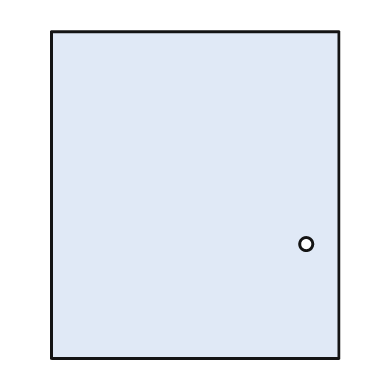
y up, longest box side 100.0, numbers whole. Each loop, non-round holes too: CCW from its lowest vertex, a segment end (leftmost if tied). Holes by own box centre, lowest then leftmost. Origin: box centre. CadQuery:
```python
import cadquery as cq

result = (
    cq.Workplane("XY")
    .moveTo(-44.0, -50.0)
    .lineTo(44.0, -50.0)
    .lineTo(44.0, 50.0)
    .lineTo(-44.0, 50.0)
    .close()
    .moveTo(34.0, -15.0)
    .circle(2.0)
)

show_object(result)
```